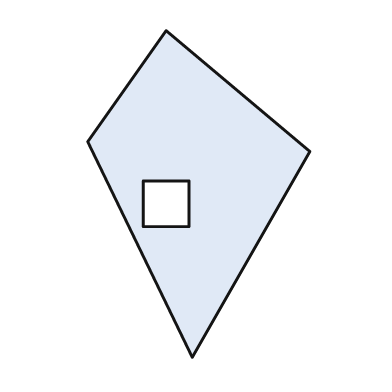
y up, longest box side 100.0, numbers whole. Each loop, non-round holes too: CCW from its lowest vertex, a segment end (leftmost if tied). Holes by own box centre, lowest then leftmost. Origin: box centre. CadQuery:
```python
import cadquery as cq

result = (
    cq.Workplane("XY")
    .moveTo(-2.0, -50.0)
    .lineTo(34.0, 13.0)
    .lineTo(-10.0, 50.0)
    .lineTo(-34.0, 16.0)
    .close()
    .moveTo(-17.0, -10.0)
    .lineTo(-3.0, -10.0)
    .lineTo(-3.0, 4.0)
    .lineTo(-17.0, 4.0)
    .close()
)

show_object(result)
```